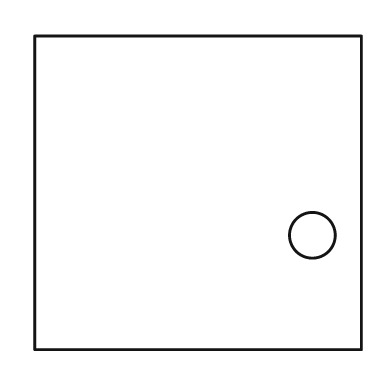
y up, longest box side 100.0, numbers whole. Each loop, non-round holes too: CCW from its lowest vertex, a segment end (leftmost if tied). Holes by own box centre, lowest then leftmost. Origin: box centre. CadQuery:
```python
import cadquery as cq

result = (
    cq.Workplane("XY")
    .moveTo(-50.0, -48.0)
    .lineTo(50.0, -48.0)
    .lineTo(50.0, 48.0)
    .lineTo(-50.0, 48.0)
    .close()
    .moveTo(35.0, -13.0)
    .circle(7.0)
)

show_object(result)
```